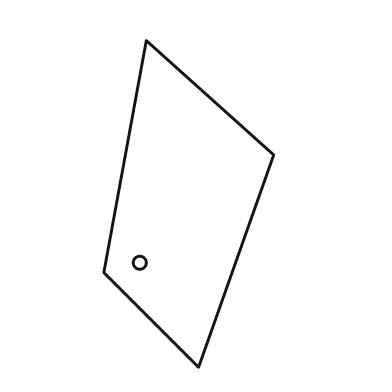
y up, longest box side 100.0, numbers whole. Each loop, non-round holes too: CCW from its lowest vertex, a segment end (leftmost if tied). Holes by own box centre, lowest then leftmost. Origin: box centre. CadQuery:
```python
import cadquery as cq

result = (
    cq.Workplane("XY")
    .moveTo(3.0, -50.0)
    .lineTo(26.0, 15.0)
    .lineTo(-13.0, 50.0)
    .lineTo(-26.0, -21.0)
    .close()
    .moveTo(-15.0, -18.0)
    .circle(2.0)
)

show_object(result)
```